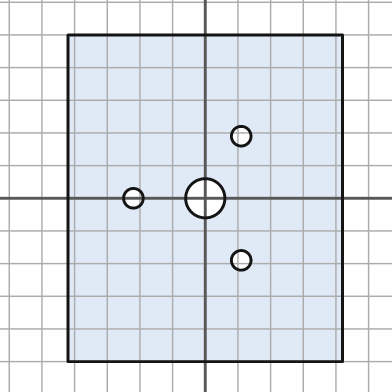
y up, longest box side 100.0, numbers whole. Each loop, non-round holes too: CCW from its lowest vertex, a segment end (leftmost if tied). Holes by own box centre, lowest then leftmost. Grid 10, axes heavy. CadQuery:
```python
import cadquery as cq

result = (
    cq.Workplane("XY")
    .moveTo(-42.0, -50.0)
    .lineTo(42.0, -50.0)
    .lineTo(42.0, 50.0)
    .lineTo(-42.0, 50.0)
    .close()
    .moveTo(11.0, -19.0)
    .circle(3.0)
    .moveTo(-22.0, 0.0)
    .circle(3.0)
    .moveTo(0.0, 0.0)
    .circle(6.0)
    .moveTo(11.0, 19.0)
    .circle(3.0)
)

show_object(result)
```